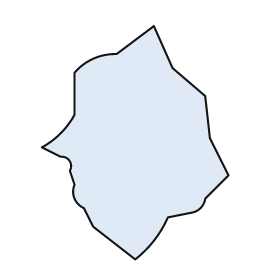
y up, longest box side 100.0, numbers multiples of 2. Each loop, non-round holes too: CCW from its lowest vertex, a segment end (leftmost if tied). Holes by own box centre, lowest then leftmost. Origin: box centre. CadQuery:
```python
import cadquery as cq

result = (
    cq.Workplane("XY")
    .moveTo(0.0, -50.0)
    .threePointArc((8.0, -42.0), (14.0, -32.0))
    .lineTo(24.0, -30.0)
    .threePointArc((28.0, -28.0), (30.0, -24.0))
    .lineTo(40.0, -14.0)
    .lineTo(32.0, 2.0)
    .lineTo(30.0, 20.0)
    .lineTo(16.0, 32.0)
    .lineTo(8.0, 50.0)
    .lineTo(-8.0, 38.0)
    .threePointArc((-18.0, 36.0), (-26.0, 30.0))
    .lineTo(-26.0, 12.0)
    .threePointArc((-32.0, 4.0), (-40.0, -2.0))
    .lineTo(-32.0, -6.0)
    .threePointArc((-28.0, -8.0), (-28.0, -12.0))
    .lineTo(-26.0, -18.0)
    .threePointArc((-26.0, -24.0), (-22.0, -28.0))
    .lineTo(-18.0, -36.0)
    .close()
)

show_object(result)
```